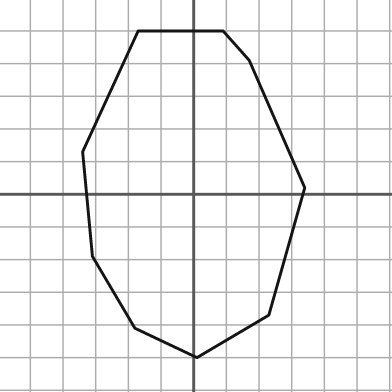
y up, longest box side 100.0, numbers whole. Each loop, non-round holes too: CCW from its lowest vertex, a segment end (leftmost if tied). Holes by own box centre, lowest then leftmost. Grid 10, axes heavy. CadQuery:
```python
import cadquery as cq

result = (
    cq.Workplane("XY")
    .moveTo(1.0, -50.0)
    .lineTo(23.0, -37.0)
    .lineTo(34.0, 2.0)
    .lineTo(17.0, 41.0)
    .lineTo(9.0, 50.0)
    .lineTo(-17.0, 50.0)
    .lineTo(-34.0, 13.0)
    .lineTo(-31.0, -19.0)
    .lineTo(-18.0, -41.0)
    .close()
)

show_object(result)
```